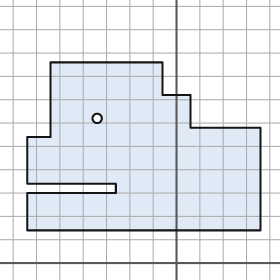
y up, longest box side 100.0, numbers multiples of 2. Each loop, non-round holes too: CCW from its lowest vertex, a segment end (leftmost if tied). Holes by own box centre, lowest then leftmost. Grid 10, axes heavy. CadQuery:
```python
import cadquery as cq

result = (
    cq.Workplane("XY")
    .moveTo(-64.0, 14.0)
    .lineTo(36.0, 14.0)
    .lineTo(36.0, 58.0)
    .lineTo(6.0, 58.0)
    .lineTo(6.0, 72.0)
    .lineTo(-6.0, 72.0)
    .lineTo(-6.0, 86.0)
    .lineTo(-54.0, 86.0)
    .lineTo(-54.0, 54.0)
    .lineTo(-64.0, 54.0)
    .lineTo(-64.0, 34.0)
    .lineTo(-26.0, 34.0)
    .lineTo(-26.0, 30.0)
    .lineTo(-64.0, 30.0)
    .close()
    .moveTo(-34.0, 62.0)
    .circle(2.0)
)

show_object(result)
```